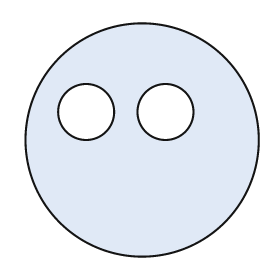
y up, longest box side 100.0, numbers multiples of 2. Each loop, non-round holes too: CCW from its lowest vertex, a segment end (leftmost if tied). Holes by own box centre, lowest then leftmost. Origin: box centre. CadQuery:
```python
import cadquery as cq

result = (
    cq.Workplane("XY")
    .moveTo(0.0, 0.0)
    .circle(50.0)
    .moveTo(-24.0, 12.0)
    .circle(12.0)
    .moveTo(10.0, 12.0)
    .circle(12.0)
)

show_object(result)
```